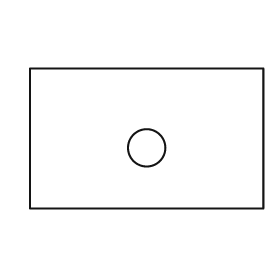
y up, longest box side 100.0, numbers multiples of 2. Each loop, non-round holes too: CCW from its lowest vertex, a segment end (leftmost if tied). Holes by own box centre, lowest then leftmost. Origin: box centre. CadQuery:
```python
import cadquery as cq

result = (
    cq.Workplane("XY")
    .moveTo(-50.0, -30.0)
    .lineTo(50.0, -30.0)
    .lineTo(50.0, 30.0)
    .lineTo(-50.0, 30.0)
    .close()
    .moveTo(0.0, -4.0)
    .circle(8.0)
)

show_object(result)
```